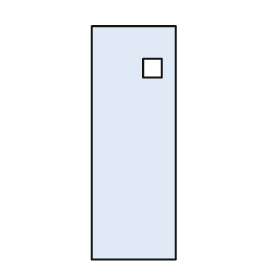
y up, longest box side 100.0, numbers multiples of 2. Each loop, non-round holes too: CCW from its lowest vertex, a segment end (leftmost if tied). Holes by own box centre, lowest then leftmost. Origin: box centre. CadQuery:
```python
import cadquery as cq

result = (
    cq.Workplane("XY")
    .moveTo(-18.0, -50.0)
    .lineTo(18.0, -50.0)
    .lineTo(18.0, 50.0)
    .lineTo(-18.0, 50.0)
    .close()
    .moveTo(4.0, 28.0)
    .lineTo(12.0, 28.0)
    .lineTo(12.0, 36.0)
    .lineTo(4.0, 36.0)
    .close()
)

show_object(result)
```